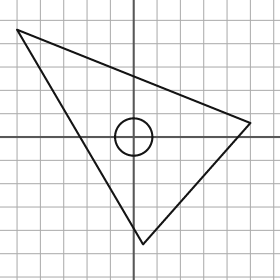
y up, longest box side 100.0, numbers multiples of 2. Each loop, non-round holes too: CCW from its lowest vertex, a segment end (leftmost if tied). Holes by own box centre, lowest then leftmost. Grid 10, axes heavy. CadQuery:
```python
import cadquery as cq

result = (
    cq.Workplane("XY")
    .moveTo(4.0, -46.0)
    .lineTo(50.0, 6.0)
    .lineTo(-50.0, 46.0)
    .close()
    .moveTo(0.0, 0.0)
    .circle(8.0)
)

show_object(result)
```